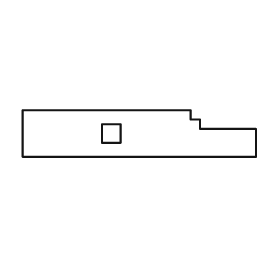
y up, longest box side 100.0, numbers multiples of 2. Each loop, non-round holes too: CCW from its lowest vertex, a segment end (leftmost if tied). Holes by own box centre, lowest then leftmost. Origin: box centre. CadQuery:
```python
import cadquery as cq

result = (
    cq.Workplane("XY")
    .moveTo(-50.0, -10.0)
    .lineTo(50.0, -10.0)
    .lineTo(50.0, 2.0)
    .lineTo(26.0, 2.0)
    .lineTo(26.0, 6.0)
    .lineTo(22.0, 6.0)
    .lineTo(22.0, 10.0)
    .lineTo(-50.0, 10.0)
    .close()
    .moveTo(-16.0, -4.0)
    .lineTo(-8.0, -4.0)
    .lineTo(-8.0, 4.0)
    .lineTo(-16.0, 4.0)
    .close()
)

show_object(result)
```